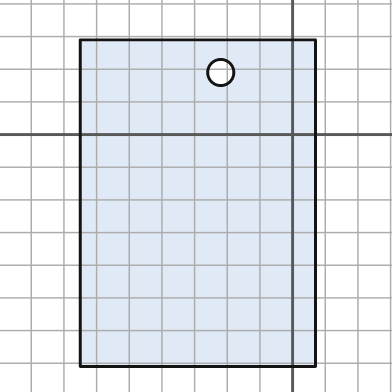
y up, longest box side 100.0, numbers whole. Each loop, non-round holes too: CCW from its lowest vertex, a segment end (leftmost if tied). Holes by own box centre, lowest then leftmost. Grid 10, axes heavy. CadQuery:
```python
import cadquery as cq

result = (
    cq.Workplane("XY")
    .moveTo(-65.0, -71.0)
    .lineTo(7.0, -71.0)
    .lineTo(7.0, 29.0)
    .lineTo(-65.0, 29.0)
    .close()
    .moveTo(-22.0, 19.0)
    .circle(4.0)
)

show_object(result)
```